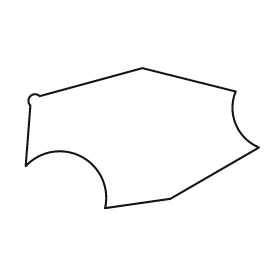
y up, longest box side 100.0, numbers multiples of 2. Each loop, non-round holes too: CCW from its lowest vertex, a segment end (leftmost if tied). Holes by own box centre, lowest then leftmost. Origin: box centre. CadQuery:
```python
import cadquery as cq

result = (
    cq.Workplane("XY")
    .moveTo(-16.0, -30.0)
    .lineTo(12.0, -26.0)
    .lineTo(50.0, -4.0)
    .threePointArc((40.0, 6.0), (40.0, 20.0))
    .lineTo(0.0, 30.0)
    .lineTo(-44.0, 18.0)
    .threePointArc((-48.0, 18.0), (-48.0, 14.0))
    .lineTo(-50.0, -12.0)
    .threePointArc((-26.0, -8.0), (-16.0, -30.0))
    .close()
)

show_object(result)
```